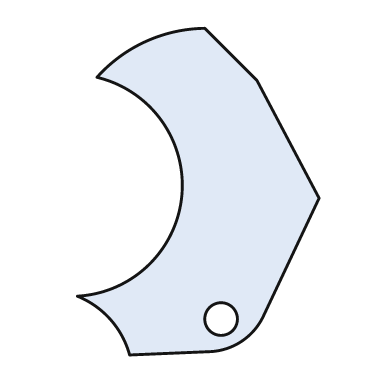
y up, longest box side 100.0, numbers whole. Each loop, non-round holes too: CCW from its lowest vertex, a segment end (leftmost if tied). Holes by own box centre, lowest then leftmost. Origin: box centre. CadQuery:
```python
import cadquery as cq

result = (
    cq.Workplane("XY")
    .moveTo(-21.0, -50.0)
    .lineTo(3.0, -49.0)
    .threePointArc((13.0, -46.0), (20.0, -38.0))
    .lineTo(37.0, -2.0)
    .lineTo(18.0, 34.0)
    .lineTo(2.0, 50.0)
    .threePointArc((-16.0, 46.0), (-31.0, 35.0))
    .threePointArc((-5.0, -1.0), (-37.0, -32.0))
    .threePointArc((-27.0, -39.0), (-21.0, -50.0))
    .close()
    .moveTo(7.0, -39.0)
    .circle(5.0)
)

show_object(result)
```